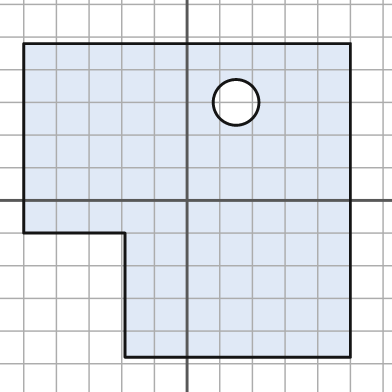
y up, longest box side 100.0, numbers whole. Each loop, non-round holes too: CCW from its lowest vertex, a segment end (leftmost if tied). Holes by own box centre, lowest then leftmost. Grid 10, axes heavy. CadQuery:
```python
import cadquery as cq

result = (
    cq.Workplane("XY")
    .moveTo(-19.0, -48.0)
    .lineTo(50.0, -48.0)
    .lineTo(50.0, 48.0)
    .lineTo(-50.0, 48.0)
    .lineTo(-50.0, -10.0)
    .lineTo(-19.0, -10.0)
    .close()
    .moveTo(15.0, 30.0)
    .circle(7.0)
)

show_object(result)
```